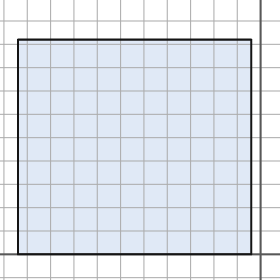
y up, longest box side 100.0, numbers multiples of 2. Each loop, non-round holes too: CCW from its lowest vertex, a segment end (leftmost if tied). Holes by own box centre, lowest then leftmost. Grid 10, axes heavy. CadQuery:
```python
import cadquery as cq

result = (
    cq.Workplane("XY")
    .moveTo(-104.0, 0.0)
    .lineTo(-4.0, 0.0)
    .lineTo(-4.0, 92.0)
    .lineTo(-104.0, 92.0)
    .close()
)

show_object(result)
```